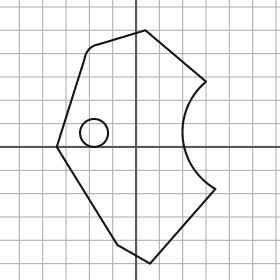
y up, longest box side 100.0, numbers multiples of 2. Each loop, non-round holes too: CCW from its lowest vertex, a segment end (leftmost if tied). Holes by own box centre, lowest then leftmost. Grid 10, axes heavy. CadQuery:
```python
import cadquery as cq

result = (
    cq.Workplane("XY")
    .moveTo(6.0, -50.0)
    .lineTo(34.0, -18.0)
    .threePointArc((20.0, 4.0), (30.0, 28.0))
    .lineTo(4.0, 50.0)
    .lineTo(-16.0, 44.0)
    .threePointArc((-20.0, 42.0), (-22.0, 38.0))
    .lineTo(-34.0, 0.0)
    .lineTo(-8.0, -42.0)
    .close()
    .moveTo(-18.0, 6.0)
    .circle(6.0)
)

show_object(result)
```